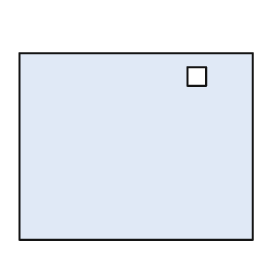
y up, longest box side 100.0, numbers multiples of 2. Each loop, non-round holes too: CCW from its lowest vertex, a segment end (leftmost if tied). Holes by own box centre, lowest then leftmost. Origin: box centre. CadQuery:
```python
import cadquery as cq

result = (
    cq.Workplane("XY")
    .moveTo(-50.0, -40.0)
    .lineTo(50.0, -40.0)
    .lineTo(50.0, 40.0)
    .lineTo(-50.0, 40.0)
    .close()
    .moveTo(22.0, 26.0)
    .lineTo(30.0, 26.0)
    .lineTo(30.0, 34.0)
    .lineTo(22.0, 34.0)
    .close()
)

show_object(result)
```